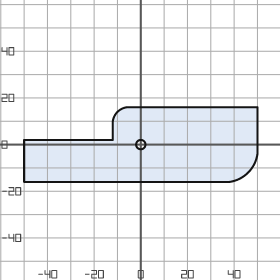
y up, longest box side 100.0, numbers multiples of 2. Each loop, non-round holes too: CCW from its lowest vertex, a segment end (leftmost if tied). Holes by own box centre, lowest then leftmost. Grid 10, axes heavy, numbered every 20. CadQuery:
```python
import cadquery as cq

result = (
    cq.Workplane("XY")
    .moveTo(-50.0, -16.0)
    .lineTo(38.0, -16.0)
    .threePointArc((46.0, -12.0), (50.0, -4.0))
    .lineTo(50.0, 16.0)
    .lineTo(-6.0, 16.0)
    .threePointArc((-10.0, 14.0), (-12.0, 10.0))
    .lineTo(-12.0, 2.0)
    .lineTo(-50.0, 2.0)
    .close()
    .moveTo(0.0, 0.0)
    .circle(2.0)
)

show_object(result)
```